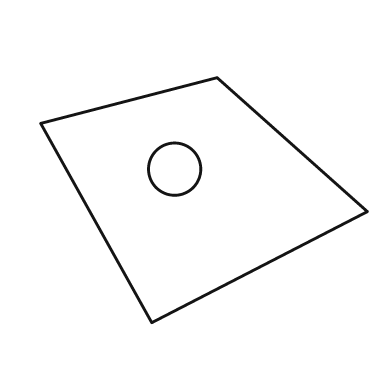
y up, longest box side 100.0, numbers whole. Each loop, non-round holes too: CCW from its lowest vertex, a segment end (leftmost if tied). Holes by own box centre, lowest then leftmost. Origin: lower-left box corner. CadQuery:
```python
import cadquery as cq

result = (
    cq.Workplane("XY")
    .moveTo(34.0, 0.0)
    .lineTo(100.0, 34.0)
    .lineTo(54.0, 75.0)
    .lineTo(0.0, 61.0)
    .close()
    .moveTo(41.0, 47.0)
    .circle(8.0)
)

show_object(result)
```